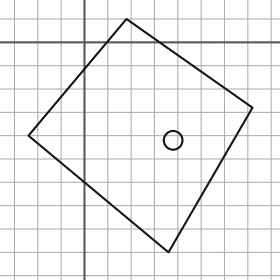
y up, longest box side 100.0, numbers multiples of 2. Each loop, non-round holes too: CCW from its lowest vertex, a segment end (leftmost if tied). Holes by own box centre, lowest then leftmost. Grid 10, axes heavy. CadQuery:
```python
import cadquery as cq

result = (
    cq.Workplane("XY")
    .moveTo(36.0, -90.0)
    .lineTo(72.0, -28.0)
    .lineTo(18.0, 10.0)
    .lineTo(-24.0, -40.0)
    .close()
    .moveTo(38.0, -42.0)
    .circle(4.0)
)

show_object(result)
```